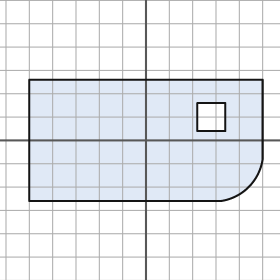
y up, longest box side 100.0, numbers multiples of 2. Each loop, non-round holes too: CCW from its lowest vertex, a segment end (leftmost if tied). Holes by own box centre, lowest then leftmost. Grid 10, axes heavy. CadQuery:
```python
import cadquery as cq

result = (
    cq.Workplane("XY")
    .moveTo(-50.0, -26.0)
    .lineTo(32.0, -26.0)
    .threePointArc((44.0, -20.0), (50.0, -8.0))
    .lineTo(50.0, 26.0)
    .lineTo(-50.0, 26.0)
    .close()
    .moveTo(22.0, 4.0)
    .lineTo(34.0, 4.0)
    .lineTo(34.0, 16.0)
    .lineTo(22.0, 16.0)
    .close()
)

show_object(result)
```